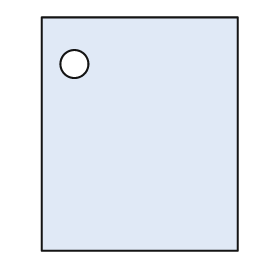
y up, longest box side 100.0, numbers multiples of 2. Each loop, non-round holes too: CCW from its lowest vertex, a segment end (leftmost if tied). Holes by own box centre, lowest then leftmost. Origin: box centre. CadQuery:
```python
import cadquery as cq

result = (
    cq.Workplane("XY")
    .moveTo(-42.0, -50.0)
    .lineTo(42.0, -50.0)
    .lineTo(42.0, 50.0)
    .lineTo(-42.0, 50.0)
    .close()
    .moveTo(-28.0, 30.0)
    .circle(6.0)
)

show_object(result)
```